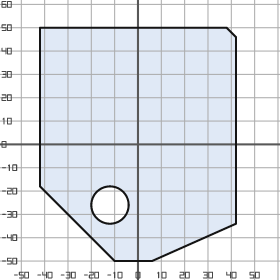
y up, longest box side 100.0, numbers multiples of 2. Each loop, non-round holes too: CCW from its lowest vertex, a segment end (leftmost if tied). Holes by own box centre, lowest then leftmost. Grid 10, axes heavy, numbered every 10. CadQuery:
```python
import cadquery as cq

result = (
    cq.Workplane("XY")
    .moveTo(-10.0, -50.0)
    .lineTo(6.0, -50.0)
    .lineTo(42.0, -34.0)
    .lineTo(42.0, 46.0)
    .lineTo(38.0, 50.0)
    .lineTo(-42.0, 50.0)
    .lineTo(-42.0, -18.0)
    .close()
    .moveTo(-12.0, -26.0)
    .circle(8.0)
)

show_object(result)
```